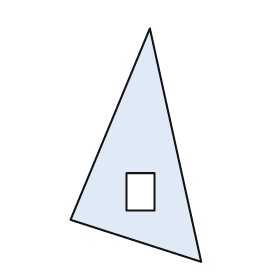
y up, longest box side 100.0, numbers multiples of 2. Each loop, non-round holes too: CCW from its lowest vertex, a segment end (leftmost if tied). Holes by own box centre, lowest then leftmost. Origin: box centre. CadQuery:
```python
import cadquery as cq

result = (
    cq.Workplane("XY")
    .moveTo(28.0, -50.0)
    .lineTo(6.0, 50.0)
    .lineTo(-28.0, -32.0)
    .close()
    .moveTo(-4.0, -28.0)
    .lineTo(8.0, -28.0)
    .lineTo(8.0, -12.0)
    .lineTo(-4.0, -12.0)
    .close()
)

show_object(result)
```